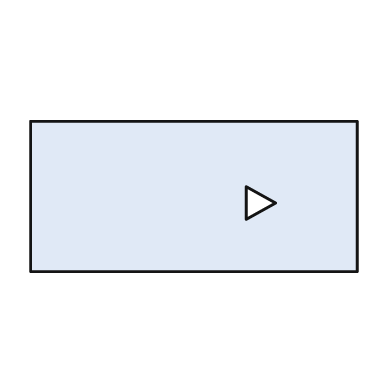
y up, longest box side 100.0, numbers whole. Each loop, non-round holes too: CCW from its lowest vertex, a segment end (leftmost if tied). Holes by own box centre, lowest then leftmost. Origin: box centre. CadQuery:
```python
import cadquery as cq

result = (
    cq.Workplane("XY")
    .moveTo(-50.0, -23.0)
    .lineTo(50.0, -23.0)
    .lineTo(50.0, 23.0)
    .lineTo(-50.0, 23.0)
    .close()
    .moveTo(16.0, -7.0)
    .lineTo(25.0, -2.0)
    .lineTo(16.0, 3.0)
    .close()
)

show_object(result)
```